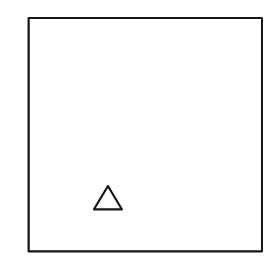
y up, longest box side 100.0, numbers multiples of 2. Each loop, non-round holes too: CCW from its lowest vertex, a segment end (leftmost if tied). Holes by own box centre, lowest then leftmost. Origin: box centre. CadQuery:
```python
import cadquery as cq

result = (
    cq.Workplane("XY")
    .moveTo(-50.0, -50.0)
    .lineTo(50.0, -50.0)
    .lineTo(50.0, 50.0)
    .lineTo(-50.0, 50.0)
    .close()
    .moveTo(-22.0, -32.0)
    .lineTo(-10.0, -32.0)
    .lineTo(-16.0, -22.0)
    .close()
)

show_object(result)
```